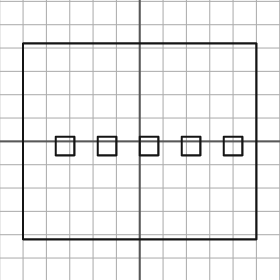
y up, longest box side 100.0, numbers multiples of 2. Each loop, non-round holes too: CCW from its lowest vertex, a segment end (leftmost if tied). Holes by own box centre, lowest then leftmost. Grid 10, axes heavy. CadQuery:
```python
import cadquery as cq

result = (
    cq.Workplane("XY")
    .moveTo(-50.0, -42.0)
    .lineTo(50.0, -42.0)
    .lineTo(50.0, 42.0)
    .lineTo(-50.0, 42.0)
    .close()
    .moveTo(-36.0, -6.0)
    .lineTo(-28.0, -6.0)
    .lineTo(-28.0, 2.0)
    .lineTo(-36.0, 2.0)
    .close()
    .moveTo(-18.0, -6.0)
    .lineTo(-10.0, -6.0)
    .lineTo(-10.0, 2.0)
    .lineTo(-18.0, 2.0)
    .close()
    .moveTo(0.0, -6.0)
    .lineTo(8.0, -6.0)
    .lineTo(8.0, 2.0)
    .lineTo(0.0, 2.0)
    .close()
    .moveTo(18.0, -6.0)
    .lineTo(26.0, -6.0)
    .lineTo(26.0, 2.0)
    .lineTo(18.0, 2.0)
    .close()
    .moveTo(36.0, -6.0)
    .lineTo(44.0, -6.0)
    .lineTo(44.0, 2.0)
    .lineTo(36.0, 2.0)
    .close()
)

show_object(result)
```